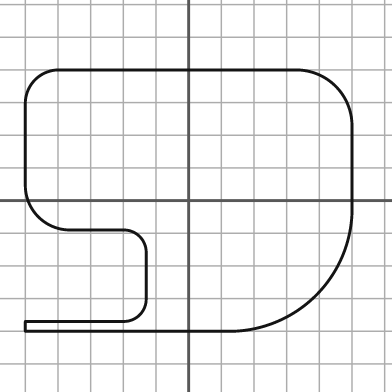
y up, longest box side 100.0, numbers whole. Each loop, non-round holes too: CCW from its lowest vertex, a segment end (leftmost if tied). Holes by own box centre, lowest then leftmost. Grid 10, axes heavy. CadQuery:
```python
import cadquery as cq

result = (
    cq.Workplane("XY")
    .moveTo(-50.0, -40.0)
    .lineTo(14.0, -40.0)
    .threePointArc((39.0, -29.0), (50.0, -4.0))
    .lineTo(50.0, 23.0)
    .threePointArc((45.0, 35.0), (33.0, 40.0))
    .lineTo(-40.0, 40.0)
    .threePointArc((-47.0, 37.0), (-50.0, 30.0))
    .lineTo(-50.0, 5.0)
    .threePointArc((-46.0, -5.0), (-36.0, -9.0))
    .lineTo(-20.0, -9.0)
    .threePointArc((-15.0, -11.0), (-13.0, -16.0))
    .lineTo(-13.0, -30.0)
    .threePointArc((-15.0, -35.0), (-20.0, -37.0))
    .lineTo(-50.0, -37.0)
    .close()
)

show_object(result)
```